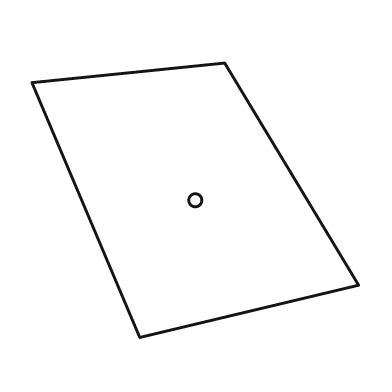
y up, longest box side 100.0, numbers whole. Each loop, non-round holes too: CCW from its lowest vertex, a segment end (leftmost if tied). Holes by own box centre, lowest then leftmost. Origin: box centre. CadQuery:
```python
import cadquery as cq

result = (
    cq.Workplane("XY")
    .moveTo(-17.0, -42.0)
    .lineTo(50.0, -26.0)
    .lineTo(9.0, 42.0)
    .lineTo(-50.0, 36.0)
    .close()
    .moveTo(0.0, 0.0)
    .circle(2.0)
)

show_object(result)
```